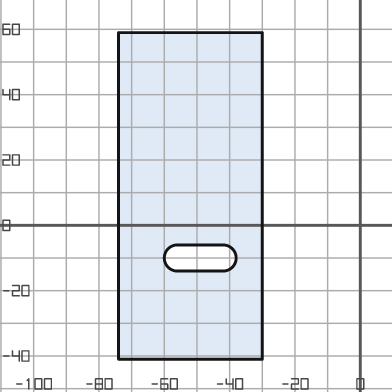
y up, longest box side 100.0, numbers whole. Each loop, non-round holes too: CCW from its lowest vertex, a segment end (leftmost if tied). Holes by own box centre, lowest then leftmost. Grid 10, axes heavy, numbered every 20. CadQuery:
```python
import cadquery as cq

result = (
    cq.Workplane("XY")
    .moveTo(-74.0, -41.0)
    .lineTo(-30.0, -41.0)
    .lineTo(-30.0, 59.0)
    .lineTo(-74.0, 59.0)
    .close()
    .moveTo(-56.0, -14.0)
    .lineTo(-42.0, -14.0)
    .threePointArc((-38.0, -10.0), (-42.0, -6.0))
    .lineTo(-56.0, -6.0)
    .threePointArc((-60.0, -10.0), (-56.0, -14.0))
    .close()
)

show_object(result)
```